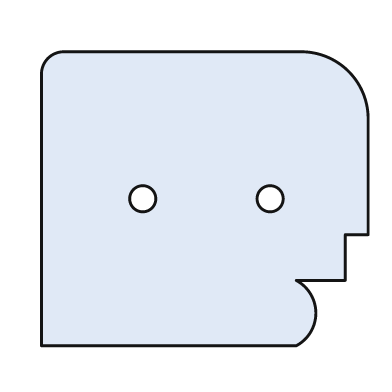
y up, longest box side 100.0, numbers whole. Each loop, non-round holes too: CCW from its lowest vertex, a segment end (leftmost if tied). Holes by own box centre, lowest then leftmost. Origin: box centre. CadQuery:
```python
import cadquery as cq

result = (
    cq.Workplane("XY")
    .moveTo(-50.0, -45.0)
    .lineTo(28.0, -45.0)
    .threePointArc((34.0, -35.0), (28.0, -25.0))
    .lineTo(43.0, -25.0)
    .lineTo(43.0, -11.0)
    .lineTo(50.0, -11.0)
    .lineTo(50.0, 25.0)
    .threePointArc((44.0, 39.0), (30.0, 45.0))
    .lineTo(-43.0, 45.0)
    .threePointArc((-48.0, 43.0), (-50.0, 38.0))
    .close()
    .moveTo(-19.0, 0.0)
    .circle(4.0)
    .moveTo(20.0, 0.0)
    .circle(4.0)
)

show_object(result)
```